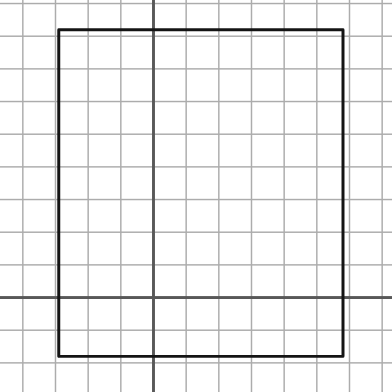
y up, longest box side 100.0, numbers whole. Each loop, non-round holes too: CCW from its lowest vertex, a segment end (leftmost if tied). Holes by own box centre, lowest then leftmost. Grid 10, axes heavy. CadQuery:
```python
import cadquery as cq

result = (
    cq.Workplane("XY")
    .moveTo(-29.0, -18.0)
    .lineTo(58.0, -18.0)
    .lineTo(58.0, 82.0)
    .lineTo(-29.0, 82.0)
    .close()
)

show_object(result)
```